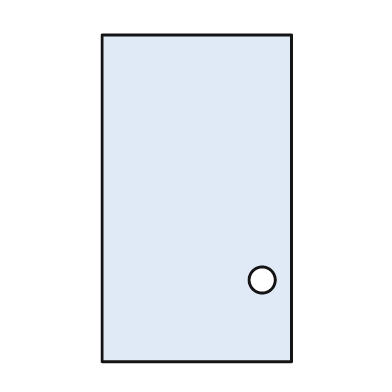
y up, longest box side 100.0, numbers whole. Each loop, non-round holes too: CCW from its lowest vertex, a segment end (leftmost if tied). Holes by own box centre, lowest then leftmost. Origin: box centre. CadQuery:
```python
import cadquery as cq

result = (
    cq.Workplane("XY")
    .moveTo(-29.0, -50.0)
    .lineTo(29.0, -50.0)
    .lineTo(29.0, 50.0)
    .lineTo(-29.0, 50.0)
    .close()
    .moveTo(20.0, -25.0)
    .circle(4.0)
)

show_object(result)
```